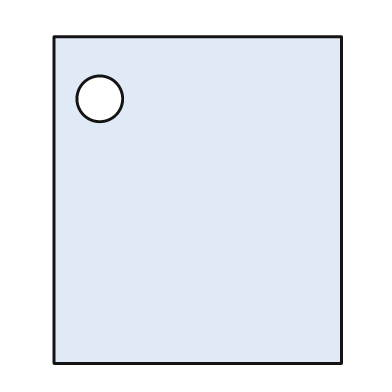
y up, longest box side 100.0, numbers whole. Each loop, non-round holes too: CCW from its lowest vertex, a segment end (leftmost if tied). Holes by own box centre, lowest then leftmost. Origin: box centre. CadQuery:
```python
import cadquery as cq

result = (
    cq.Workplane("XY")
    .moveTo(-44.0, -50.0)
    .lineTo(44.0, -50.0)
    .lineTo(44.0, 50.0)
    .lineTo(-44.0, 50.0)
    .close()
    .moveTo(-30.0, 31.0)
    .circle(7.0)
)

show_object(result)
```